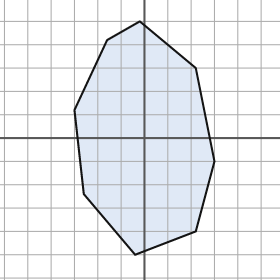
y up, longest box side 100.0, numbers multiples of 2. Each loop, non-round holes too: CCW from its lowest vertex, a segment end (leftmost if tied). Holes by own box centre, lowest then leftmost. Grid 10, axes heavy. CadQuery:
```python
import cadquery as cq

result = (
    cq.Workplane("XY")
    .moveTo(-4.0, -50.0)
    .lineTo(22.0, -40.0)
    .lineTo(30.0, -10.0)
    .lineTo(22.0, 30.0)
    .lineTo(-2.0, 50.0)
    .lineTo(-16.0, 42.0)
    .lineTo(-30.0, 12.0)
    .lineTo(-26.0, -24.0)
    .close()
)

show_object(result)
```